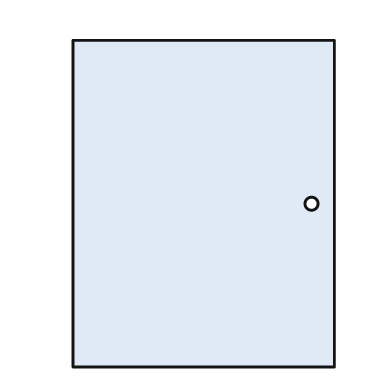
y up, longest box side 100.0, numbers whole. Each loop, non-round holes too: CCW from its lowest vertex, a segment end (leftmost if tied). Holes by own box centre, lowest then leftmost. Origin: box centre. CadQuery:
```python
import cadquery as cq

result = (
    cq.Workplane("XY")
    .moveTo(-40.0, -50.0)
    .lineTo(40.0, -50.0)
    .lineTo(40.0, 50.0)
    .lineTo(-40.0, 50.0)
    .close()
    .moveTo(33.0, 0.0)
    .circle(2.0)
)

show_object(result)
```